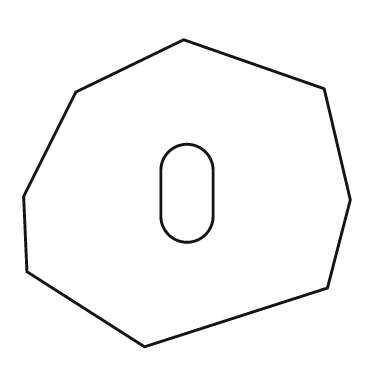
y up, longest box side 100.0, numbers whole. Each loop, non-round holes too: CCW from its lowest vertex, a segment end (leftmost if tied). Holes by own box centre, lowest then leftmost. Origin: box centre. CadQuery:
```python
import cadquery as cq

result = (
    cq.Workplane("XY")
    .moveTo(-13.0, -47.0)
    .lineTo(43.0, -29.0)
    .lineTo(50.0, -2.0)
    .lineTo(42.0, 32.0)
    .lineTo(-1.0, 47.0)
    .lineTo(-34.0, 31.0)
    .lineTo(-50.0, -1.0)
    .lineTo(-49.0, -24.0)
    .close()
    .moveTo(-8.0, -7.0)
    .threePointArc((0.0, -15.0), (8.0, -7.0))
    .lineTo(8.0, 7.0)
    .threePointArc((0.0, 15.0), (-8.0, 7.0))
    .close()
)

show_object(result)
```